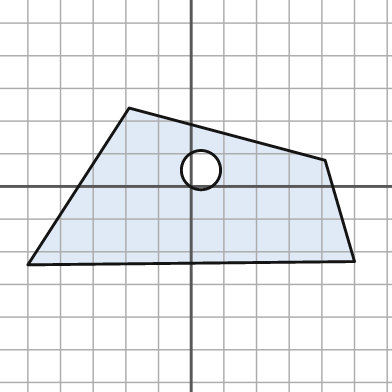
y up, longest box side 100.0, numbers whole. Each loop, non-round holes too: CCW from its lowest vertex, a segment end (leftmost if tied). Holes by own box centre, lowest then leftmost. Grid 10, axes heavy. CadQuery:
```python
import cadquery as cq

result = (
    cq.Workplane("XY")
    .moveTo(-50.0, -24.0)
    .lineTo(50.0, -23.0)
    .lineTo(41.0, 8.0)
    .lineTo(-19.0, 24.0)
    .close()
    .moveTo(3.0, 5.0)
    .circle(6.0)
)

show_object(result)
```